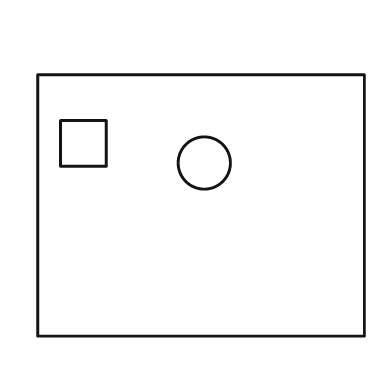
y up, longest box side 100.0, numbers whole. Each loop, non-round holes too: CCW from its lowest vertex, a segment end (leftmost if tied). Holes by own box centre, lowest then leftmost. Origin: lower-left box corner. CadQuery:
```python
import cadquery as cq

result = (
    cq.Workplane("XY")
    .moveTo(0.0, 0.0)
    .lineTo(100.0, 0.0)
    .lineTo(100.0, 80.0)
    .lineTo(0.0, 80.0)
    .close()
    .moveTo(51.0, 53.0)
    .circle(8.0)
    .moveTo(7.0, 52.0)
    .lineTo(21.0, 52.0)
    .lineTo(21.0, 66.0)
    .lineTo(7.0, 66.0)
    .close()
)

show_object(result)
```